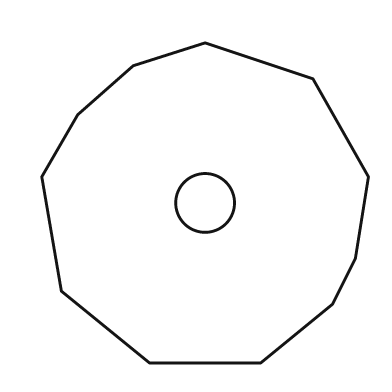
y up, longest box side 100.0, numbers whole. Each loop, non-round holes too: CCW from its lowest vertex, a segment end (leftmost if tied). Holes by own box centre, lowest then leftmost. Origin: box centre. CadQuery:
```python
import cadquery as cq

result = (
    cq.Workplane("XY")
    .moveTo(-17.0, -49.0)
    .lineTo(17.0, -49.0)
    .lineTo(39.0, -31.0)
    .lineTo(46.0, -17.0)
    .lineTo(50.0, 8.0)
    .lineTo(33.0, 38.0)
    .lineTo(0.0, 49.0)
    .lineTo(-22.0, 42.0)
    .lineTo(-39.0, 27.0)
    .lineTo(-50.0, 8.0)
    .lineTo(-44.0, -27.0)
    .close()
    .moveTo(0.0, 0.0)
    .circle(9.0)
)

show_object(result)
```